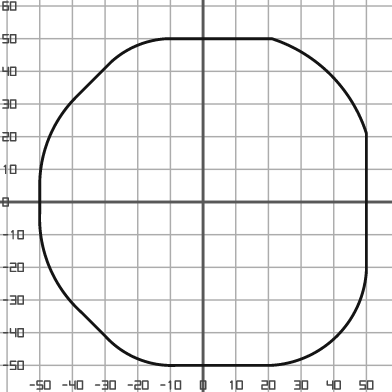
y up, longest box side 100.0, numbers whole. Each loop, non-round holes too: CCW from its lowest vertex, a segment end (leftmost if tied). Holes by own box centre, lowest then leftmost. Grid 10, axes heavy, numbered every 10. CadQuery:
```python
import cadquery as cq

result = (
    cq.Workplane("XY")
    .moveTo(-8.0, -50.0)
    .lineTo(21.0, -50.0)
    .threePointArc((41.0, -41.0), (50.0, -21.0))
    .lineTo(50.0, 21.0)
    .threePointArc((39.0, 39.0), (21.0, 50.0))
    .lineTo(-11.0, 50.0)
    .threePointArc((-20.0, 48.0), (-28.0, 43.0))
    .lineTo(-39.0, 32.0)
    .threePointArc((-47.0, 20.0), (-50.0, 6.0))
    .lineTo(-50.0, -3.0)
    .threePointArc((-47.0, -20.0), (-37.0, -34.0))
    .lineTo(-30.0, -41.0)
    .threePointArc((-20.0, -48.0), (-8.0, -50.0))
    .close()
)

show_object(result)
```